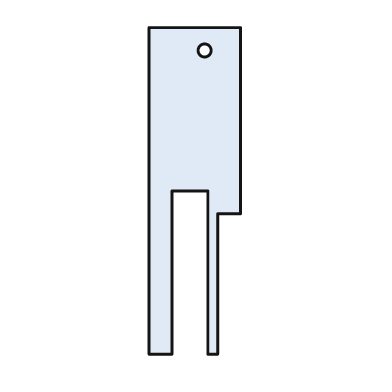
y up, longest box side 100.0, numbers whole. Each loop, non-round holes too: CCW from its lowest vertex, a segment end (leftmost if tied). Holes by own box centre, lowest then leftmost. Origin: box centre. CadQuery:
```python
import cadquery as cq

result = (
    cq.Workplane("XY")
    .moveTo(-14.0, -50.0)
    .lineTo(-7.0, -50.0)
    .lineTo(-7.0, 0.0)
    .lineTo(4.0, 0.0)
    .lineTo(4.0, -50.0)
    .lineTo(7.0, -50.0)
    .lineTo(7.0, -7.0)
    .lineTo(14.0, -7.0)
    .lineTo(14.0, 50.0)
    .lineTo(-14.0, 50.0)
    .close()
    .moveTo(3.0, 43.0)
    .circle(2.0)
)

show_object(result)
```